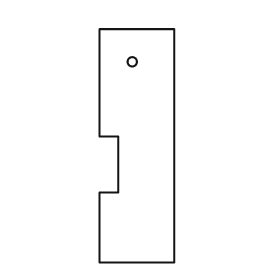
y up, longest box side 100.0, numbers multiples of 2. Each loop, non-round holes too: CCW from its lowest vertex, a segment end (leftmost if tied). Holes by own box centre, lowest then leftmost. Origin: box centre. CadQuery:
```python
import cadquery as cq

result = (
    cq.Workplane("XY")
    .moveTo(-16.0, -50.0)
    .lineTo(16.0, -50.0)
    .lineTo(16.0, 50.0)
    .lineTo(-16.0, 50.0)
    .lineTo(-16.0, 4.0)
    .lineTo(-8.0, 4.0)
    .lineTo(-8.0, -20.0)
    .lineTo(-16.0, -20.0)
    .close()
    .moveTo(-2.0, 36.0)
    .circle(2.0)
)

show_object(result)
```